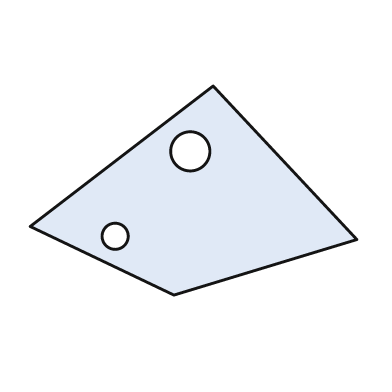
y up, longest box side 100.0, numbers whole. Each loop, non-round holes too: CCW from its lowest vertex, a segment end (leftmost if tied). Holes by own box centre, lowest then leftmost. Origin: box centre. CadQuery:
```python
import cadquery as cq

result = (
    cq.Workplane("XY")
    .moveTo(-6.0, -32.0)
    .lineTo(50.0, -15.0)
    .lineTo(6.0, 32.0)
    .lineTo(-50.0, -11.0)
    .close()
    .moveTo(-24.0, -14.0)
    .circle(4.0)
    .moveTo(-1.0, 12.0)
    .circle(6.0)
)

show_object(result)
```